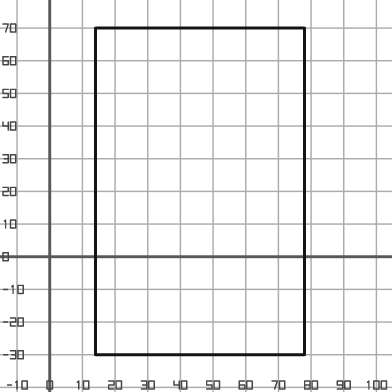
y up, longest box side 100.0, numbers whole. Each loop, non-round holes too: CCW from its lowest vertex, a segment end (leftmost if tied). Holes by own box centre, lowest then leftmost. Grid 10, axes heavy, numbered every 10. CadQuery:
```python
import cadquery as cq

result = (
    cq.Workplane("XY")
    .moveTo(14.0, -30.0)
    .lineTo(78.0, -30.0)
    .lineTo(78.0, 70.0)
    .lineTo(14.0, 70.0)
    .close()
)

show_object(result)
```